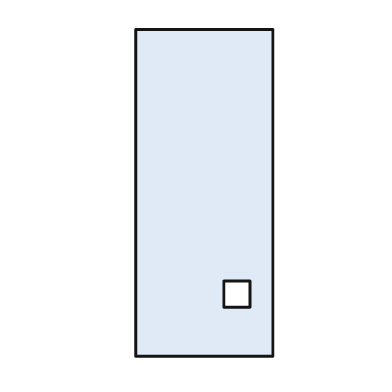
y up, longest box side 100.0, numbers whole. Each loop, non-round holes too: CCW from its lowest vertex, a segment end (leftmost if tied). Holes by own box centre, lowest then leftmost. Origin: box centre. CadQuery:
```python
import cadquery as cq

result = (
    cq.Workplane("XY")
    .moveTo(-21.0, -50.0)
    .lineTo(21.0, -50.0)
    .lineTo(21.0, 50.0)
    .lineTo(-21.0, 50.0)
    .close()
    .moveTo(6.0, -35.0)
    .lineTo(14.0, -35.0)
    .lineTo(14.0, -27.0)
    .lineTo(6.0, -27.0)
    .close()
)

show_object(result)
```